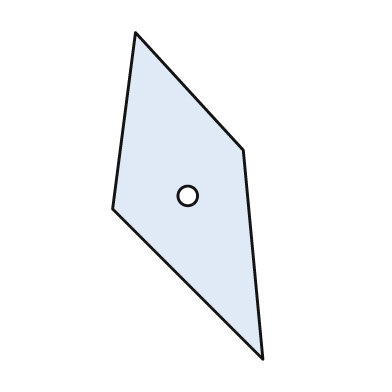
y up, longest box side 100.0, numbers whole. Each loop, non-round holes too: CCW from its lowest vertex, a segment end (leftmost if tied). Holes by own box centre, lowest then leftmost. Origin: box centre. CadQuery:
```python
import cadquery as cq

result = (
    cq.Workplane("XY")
    .moveTo(23.0, -50.0)
    .lineTo(17.0, 14.0)
    .lineTo(-16.0, 50.0)
    .lineTo(-23.0, -4.0)
    .close()
    .moveTo(0.0, 0.0)
    .circle(3.0)
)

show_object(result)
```